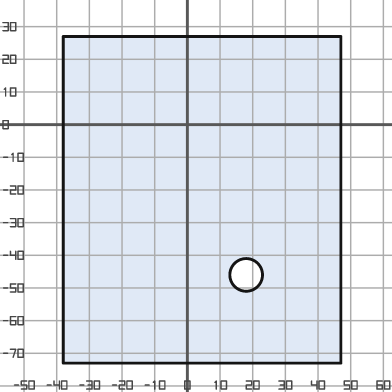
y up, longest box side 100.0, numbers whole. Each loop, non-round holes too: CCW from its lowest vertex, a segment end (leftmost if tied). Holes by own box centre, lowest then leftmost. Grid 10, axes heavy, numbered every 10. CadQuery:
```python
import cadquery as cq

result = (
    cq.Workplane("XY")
    .moveTo(-38.0, -73.0)
    .lineTo(47.0, -73.0)
    .lineTo(47.0, 27.0)
    .lineTo(-38.0, 27.0)
    .close()
    .moveTo(18.0, -46.0)
    .circle(5.0)
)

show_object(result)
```